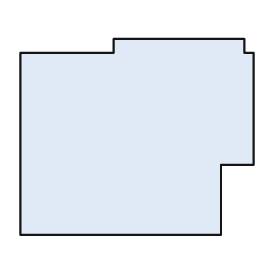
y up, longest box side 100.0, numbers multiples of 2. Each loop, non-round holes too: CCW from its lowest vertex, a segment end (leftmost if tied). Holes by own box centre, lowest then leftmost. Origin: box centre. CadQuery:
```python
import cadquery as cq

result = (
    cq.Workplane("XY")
    .moveTo(-50.0, -42.0)
    .lineTo(36.0, -42.0)
    .lineTo(36.0, -12.0)
    .lineTo(50.0, -12.0)
    .lineTo(50.0, 36.0)
    .lineTo(46.0, 36.0)
    .lineTo(46.0, 42.0)
    .lineTo(-10.0, 42.0)
    .lineTo(-10.0, 36.0)
    .lineTo(-50.0, 36.0)
    .close()
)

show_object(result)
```